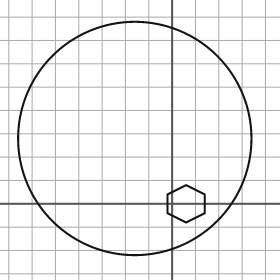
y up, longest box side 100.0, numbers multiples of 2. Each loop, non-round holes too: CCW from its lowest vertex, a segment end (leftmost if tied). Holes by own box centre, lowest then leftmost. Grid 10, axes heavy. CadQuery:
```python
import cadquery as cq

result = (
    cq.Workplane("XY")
    .moveTo(-16.0, 28.0)
    .circle(50.0)
    .moveTo(6.0, -8.0)
    .lineTo(14.0, -4.0)
    .lineTo(14.0, 4.0)
    .lineTo(6.0, 8.0)
    .lineTo(-2.0, 4.0)
    .lineTo(-2.0, -4.0)
    .close()
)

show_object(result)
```